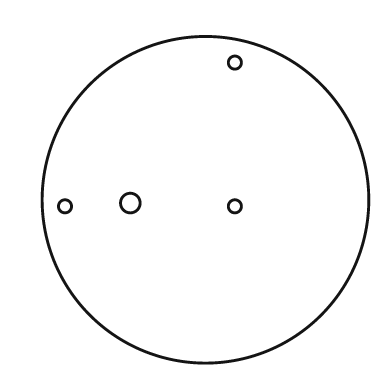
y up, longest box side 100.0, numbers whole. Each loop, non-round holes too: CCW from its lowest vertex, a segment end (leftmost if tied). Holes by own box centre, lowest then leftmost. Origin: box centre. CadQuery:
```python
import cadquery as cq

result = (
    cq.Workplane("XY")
    .moveTo(0.0, 0.0)
    .circle(50.0)
    .moveTo(-43.0, -2.0)
    .circle(2.0)
    .moveTo(9.0, -2.0)
    .circle(2.0)
    .moveTo(-23.0, -1.0)
    .circle(3.0)
    .moveTo(9.0, 42.0)
    .circle(2.0)
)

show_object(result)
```